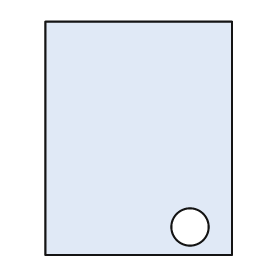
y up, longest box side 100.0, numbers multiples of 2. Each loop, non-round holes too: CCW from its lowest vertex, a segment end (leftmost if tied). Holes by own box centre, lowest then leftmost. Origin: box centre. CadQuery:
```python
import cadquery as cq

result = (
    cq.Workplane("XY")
    .moveTo(-40.0, -50.0)
    .lineTo(40.0, -50.0)
    .lineTo(40.0, 50.0)
    .lineTo(-40.0, 50.0)
    .close()
    .moveTo(22.0, -38.0)
    .circle(8.0)
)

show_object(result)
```